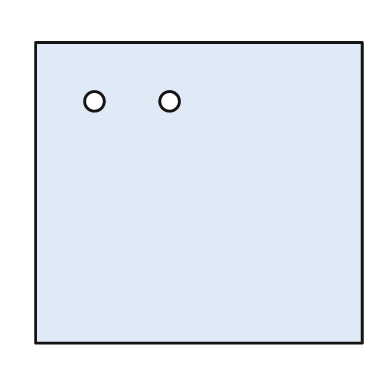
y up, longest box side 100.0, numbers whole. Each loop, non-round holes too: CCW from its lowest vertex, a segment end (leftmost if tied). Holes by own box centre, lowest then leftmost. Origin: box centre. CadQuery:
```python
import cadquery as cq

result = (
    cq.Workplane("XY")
    .moveTo(-50.0, -46.0)
    .lineTo(50.0, -46.0)
    .lineTo(50.0, 46.0)
    .lineTo(-50.0, 46.0)
    .close()
    .moveTo(-32.0, 28.0)
    .circle(3.0)
    .moveTo(-9.0, 28.0)
    .circle(3.0)
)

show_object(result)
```